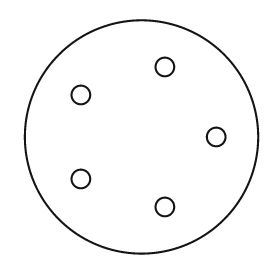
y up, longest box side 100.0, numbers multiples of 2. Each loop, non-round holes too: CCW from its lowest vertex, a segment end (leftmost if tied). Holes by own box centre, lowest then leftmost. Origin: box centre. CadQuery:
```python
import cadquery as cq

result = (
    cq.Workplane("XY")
    .moveTo(0.0, 0.0)
    .circle(50.0)
    .moveTo(10.0, -30.0)
    .circle(4.0)
    .moveTo(-26.0, -18.0)
    .circle(4.0)
    .moveTo(32.0, 0.0)
    .circle(4.0)
    .moveTo(-26.0, 18.0)
    .circle(4.0)
    .moveTo(10.0, 30.0)
    .circle(4.0)
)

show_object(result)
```